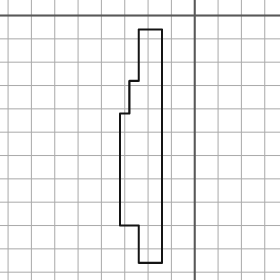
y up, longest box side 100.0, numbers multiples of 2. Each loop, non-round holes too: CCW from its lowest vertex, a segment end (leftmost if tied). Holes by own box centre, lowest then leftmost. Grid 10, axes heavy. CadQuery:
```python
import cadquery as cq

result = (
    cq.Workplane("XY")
    .moveTo(-24.0, -106.0)
    .lineTo(-14.0, -106.0)
    .lineTo(-14.0, -6.0)
    .lineTo(-24.0, -6.0)
    .lineTo(-24.0, -28.0)
    .lineTo(-28.0, -28.0)
    .lineTo(-28.0, -42.0)
    .lineTo(-32.0, -42.0)
    .lineTo(-32.0, -90.0)
    .lineTo(-24.0, -90.0)
    .close()
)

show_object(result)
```